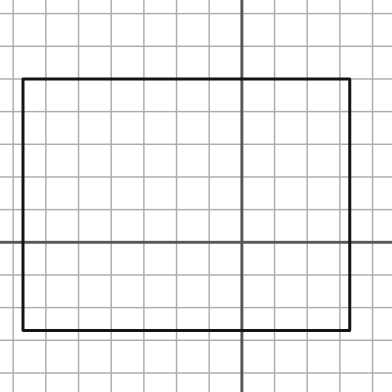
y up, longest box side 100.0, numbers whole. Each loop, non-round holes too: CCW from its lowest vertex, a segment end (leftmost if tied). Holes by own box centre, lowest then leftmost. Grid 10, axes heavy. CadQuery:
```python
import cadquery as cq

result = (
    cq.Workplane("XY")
    .moveTo(-67.0, -27.0)
    .lineTo(33.0, -27.0)
    .lineTo(33.0, 50.0)
    .lineTo(-67.0, 50.0)
    .close()
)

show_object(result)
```